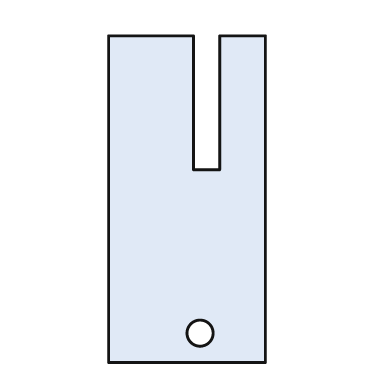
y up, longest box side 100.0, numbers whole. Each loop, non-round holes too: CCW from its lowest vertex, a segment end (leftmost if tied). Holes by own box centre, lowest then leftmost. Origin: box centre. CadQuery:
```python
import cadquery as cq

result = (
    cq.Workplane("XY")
    .moveTo(-24.0, -50.0)
    .lineTo(24.0, -50.0)
    .lineTo(24.0, 50.0)
    .lineTo(10.0, 50.0)
    .lineTo(10.0, 9.0)
    .lineTo(2.0, 9.0)
    .lineTo(2.0, 50.0)
    .lineTo(-24.0, 50.0)
    .close()
    .moveTo(4.0, -41.0)
    .circle(4.0)
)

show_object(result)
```